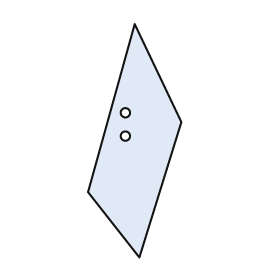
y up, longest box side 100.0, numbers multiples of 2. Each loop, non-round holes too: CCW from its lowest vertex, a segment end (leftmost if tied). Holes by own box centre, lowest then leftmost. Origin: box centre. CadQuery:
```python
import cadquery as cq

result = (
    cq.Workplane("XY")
    .moveTo(2.0, -50.0)
    .lineTo(20.0, 8.0)
    .lineTo(0.0, 50.0)
    .lineTo(-20.0, -22.0)
    .close()
    .moveTo(-4.0, 2.0)
    .circle(2.0)
    .moveTo(-4.0, 12.0)
    .circle(2.0)
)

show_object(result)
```